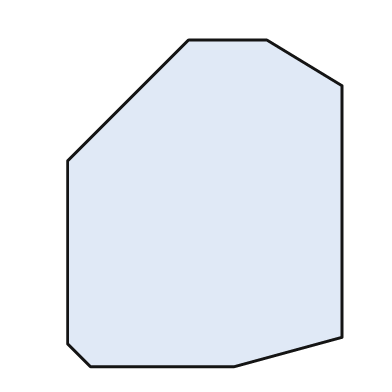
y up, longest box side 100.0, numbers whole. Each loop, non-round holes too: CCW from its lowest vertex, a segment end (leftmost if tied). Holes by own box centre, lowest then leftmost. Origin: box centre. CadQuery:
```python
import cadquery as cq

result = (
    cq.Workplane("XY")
    .moveTo(-35.0, -50.0)
    .lineTo(9.0, -50.0)
    .lineTo(42.0, -41.0)
    .lineTo(42.0, 36.0)
    .lineTo(19.0, 50.0)
    .lineTo(-5.0, 50.0)
    .lineTo(-42.0, 13.0)
    .lineTo(-42.0, -43.0)
    .close()
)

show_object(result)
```